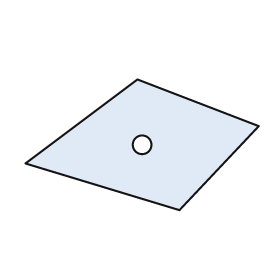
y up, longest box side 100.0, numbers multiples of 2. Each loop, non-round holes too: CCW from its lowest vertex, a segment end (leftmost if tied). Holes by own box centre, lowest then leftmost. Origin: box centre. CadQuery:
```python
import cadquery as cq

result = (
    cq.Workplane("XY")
    .moveTo(16.0, -28.0)
    .lineTo(50.0, 8.0)
    .lineTo(-2.0, 28.0)
    .lineTo(-50.0, -8.0)
    .close()
    .moveTo(0.0, 0.0)
    .circle(4.0)
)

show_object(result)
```